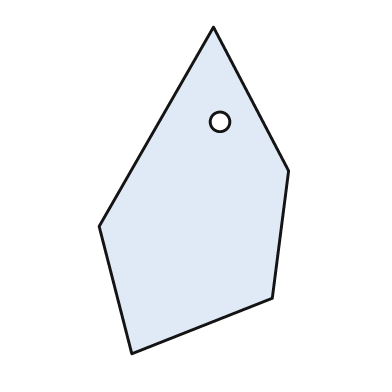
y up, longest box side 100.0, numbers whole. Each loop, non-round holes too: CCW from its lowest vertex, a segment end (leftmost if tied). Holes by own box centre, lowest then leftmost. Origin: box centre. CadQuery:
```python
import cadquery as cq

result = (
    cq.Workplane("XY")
    .moveTo(-19.0, -50.0)
    .lineTo(24.0, -33.0)
    .lineTo(29.0, 6.0)
    .lineTo(6.0, 50.0)
    .lineTo(-29.0, -11.0)
    .close()
    .moveTo(8.0, 21.0)
    .circle(3.0)
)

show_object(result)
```